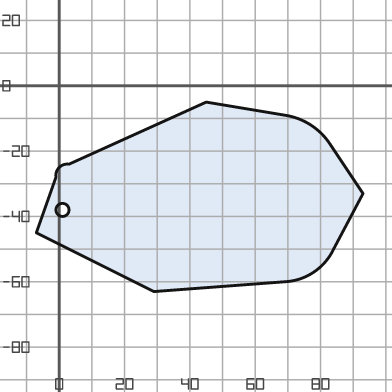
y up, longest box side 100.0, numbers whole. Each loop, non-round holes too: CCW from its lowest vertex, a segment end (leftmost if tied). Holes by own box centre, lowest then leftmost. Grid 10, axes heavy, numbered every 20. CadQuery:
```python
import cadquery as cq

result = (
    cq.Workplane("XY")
    .moveTo(29.0, -63.0)
    .lineTo(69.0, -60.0)
    .threePointArc((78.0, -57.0), (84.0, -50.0))
    .lineTo(93.0, -33.0)
    .lineTo(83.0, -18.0)
    .threePointArc((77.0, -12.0), (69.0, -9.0))
    .lineTo(45.0, -5.0)
    .lineTo(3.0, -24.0)
    .threePointArc((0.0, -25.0), (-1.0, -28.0))
    .lineTo(-7.0, -45.0)
    .close()
    .moveTo(1.0, -38.0)
    .circle(2.0)
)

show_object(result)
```